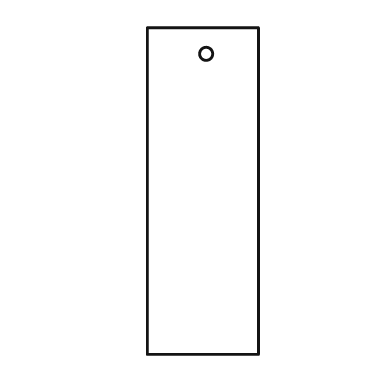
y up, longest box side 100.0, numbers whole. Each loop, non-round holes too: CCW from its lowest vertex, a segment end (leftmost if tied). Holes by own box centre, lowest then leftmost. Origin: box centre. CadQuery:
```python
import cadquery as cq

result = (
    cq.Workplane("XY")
    .moveTo(-17.0, -50.0)
    .lineTo(17.0, -50.0)
    .lineTo(17.0, 50.0)
    .lineTo(-17.0, 50.0)
    .close()
    .moveTo(1.0, 42.0)
    .circle(2.0)
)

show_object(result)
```